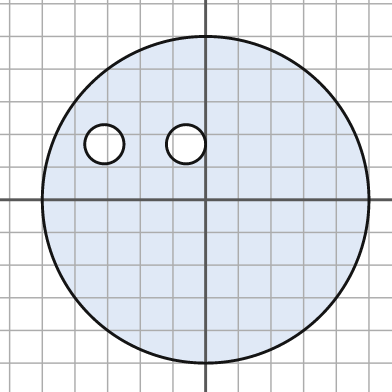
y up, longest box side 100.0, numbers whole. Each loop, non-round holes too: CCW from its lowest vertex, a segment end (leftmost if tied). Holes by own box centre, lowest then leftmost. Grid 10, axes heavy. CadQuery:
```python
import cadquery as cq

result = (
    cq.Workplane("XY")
    .moveTo(0.0, 0.0)
    .circle(50.0)
    .moveTo(-31.0, 17.0)
    .circle(6.0)
    .moveTo(-6.0, 17.0)
    .circle(6.0)
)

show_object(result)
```